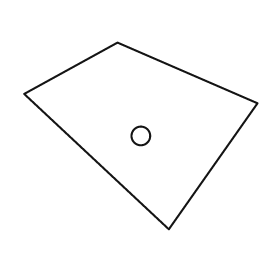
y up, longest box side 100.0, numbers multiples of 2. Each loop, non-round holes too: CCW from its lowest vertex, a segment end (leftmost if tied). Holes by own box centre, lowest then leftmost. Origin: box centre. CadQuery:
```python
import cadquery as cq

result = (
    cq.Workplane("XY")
    .moveTo(12.0, -40.0)
    .lineTo(50.0, 14.0)
    .lineTo(-10.0, 40.0)
    .lineTo(-50.0, 18.0)
    .close()
    .moveTo(0.0, 0.0)
    .circle(4.0)
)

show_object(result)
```